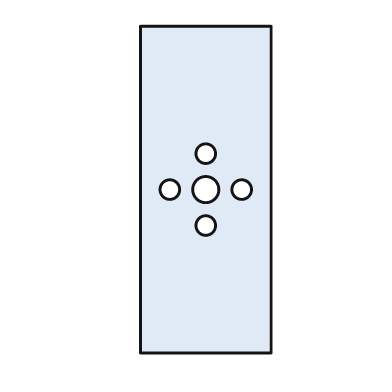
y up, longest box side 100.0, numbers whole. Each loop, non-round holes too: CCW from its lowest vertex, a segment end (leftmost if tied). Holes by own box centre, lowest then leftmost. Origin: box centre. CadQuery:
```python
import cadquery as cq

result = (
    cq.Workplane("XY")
    .moveTo(-20.0, -50.0)
    .lineTo(20.0, -50.0)
    .lineTo(20.0, 50.0)
    .lineTo(-20.0, 50.0)
    .close()
    .moveTo(0.0, -11.0)
    .circle(3.0)
    .moveTo(-11.0, 0.0)
    .circle(3.0)
    .moveTo(0.0, 0.0)
    .circle(4.0)
    .moveTo(11.0, 0.0)
    .circle(3.0)
    .moveTo(0.0, 11.0)
    .circle(3.0)
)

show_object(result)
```